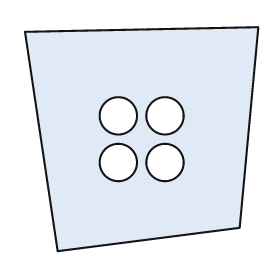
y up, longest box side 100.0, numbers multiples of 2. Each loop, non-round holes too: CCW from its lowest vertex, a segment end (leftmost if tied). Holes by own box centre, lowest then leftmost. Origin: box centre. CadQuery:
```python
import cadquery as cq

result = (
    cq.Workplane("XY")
    .moveTo(-36.0, -48.0)
    .lineTo(42.0, -38.0)
    .lineTo(50.0, 48.0)
    .lineTo(-50.0, 46.0)
    .close()
    .moveTo(-10.0, -10.0)
    .circle(8.0)
    .moveTo(10.0, -10.0)
    .circle(8.0)
    .moveTo(-10.0, 10.0)
    .circle(8.0)
    .moveTo(10.0, 10.0)
    .circle(8.0)
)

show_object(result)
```